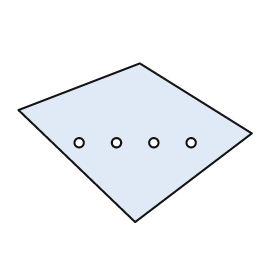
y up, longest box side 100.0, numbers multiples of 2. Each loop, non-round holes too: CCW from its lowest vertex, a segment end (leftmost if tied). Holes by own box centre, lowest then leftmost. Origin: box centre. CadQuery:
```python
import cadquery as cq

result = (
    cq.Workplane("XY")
    .moveTo(0.0, -34.0)
    .lineTo(50.0, 4.0)
    .lineTo(2.0, 34.0)
    .lineTo(-50.0, 14.0)
    .close()
    .moveTo(-24.0, 0.0)
    .circle(2.0)
    .moveTo(-8.0, 0.0)
    .circle(2.0)
    .moveTo(8.0, 0.0)
    .circle(2.0)
    .moveTo(24.0, 0.0)
    .circle(2.0)
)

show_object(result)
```